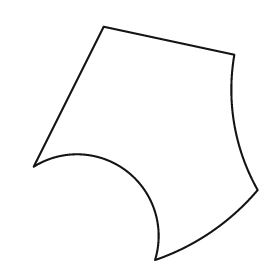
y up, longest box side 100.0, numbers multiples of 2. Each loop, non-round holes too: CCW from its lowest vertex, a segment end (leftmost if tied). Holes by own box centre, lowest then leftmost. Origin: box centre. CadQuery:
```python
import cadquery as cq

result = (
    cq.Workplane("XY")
    .moveTo(4.0, -50.0)
    .threePointArc((28.0, -38.0), (48.0, -20.0))
    .threePointArc((38.0, 8.0), (38.0, 38.0))
    .lineTo(-18.0, 50.0)
    .lineTo(-48.0, -10.0)
    .threePointArc((-8.0, -12.0), (4.0, -50.0))
    .close()
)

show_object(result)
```